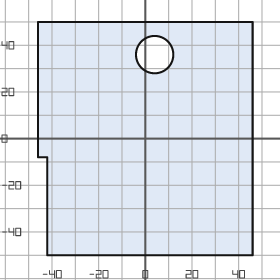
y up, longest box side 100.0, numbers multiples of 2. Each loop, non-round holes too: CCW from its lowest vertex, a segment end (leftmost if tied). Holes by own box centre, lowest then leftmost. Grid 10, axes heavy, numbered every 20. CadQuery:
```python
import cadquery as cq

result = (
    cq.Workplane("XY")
    .moveTo(-42.0, -50.0)
    .lineTo(46.0, -50.0)
    .lineTo(46.0, 50.0)
    .lineTo(-46.0, 50.0)
    .lineTo(-46.0, -8.0)
    .lineTo(-42.0, -8.0)
    .close()
    .moveTo(4.0, 36.0)
    .circle(8.0)
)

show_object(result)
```